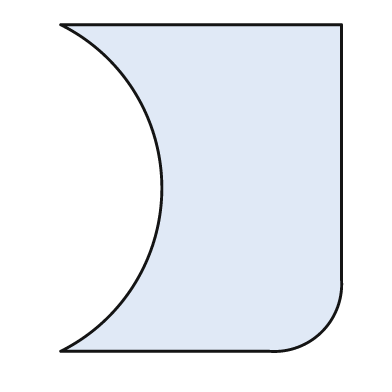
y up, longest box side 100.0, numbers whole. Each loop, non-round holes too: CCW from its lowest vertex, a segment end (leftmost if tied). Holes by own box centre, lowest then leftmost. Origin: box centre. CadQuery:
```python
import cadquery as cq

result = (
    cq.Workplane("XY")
    .moveTo(-43.0, -50.0)
    .lineTo(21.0, -50.0)
    .threePointArc((37.0, -44.0), (43.0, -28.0))
    .lineTo(43.0, 50.0)
    .lineTo(-43.0, 50.0)
    .threePointArc((-12.0, 0.0), (-43.0, -50.0))
    .close()
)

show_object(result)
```